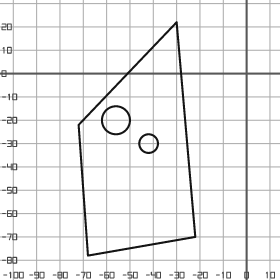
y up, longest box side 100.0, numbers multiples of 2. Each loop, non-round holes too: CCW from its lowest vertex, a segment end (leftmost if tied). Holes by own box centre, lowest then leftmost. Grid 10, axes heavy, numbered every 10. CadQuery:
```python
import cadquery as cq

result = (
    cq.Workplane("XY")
    .moveTo(-68.0, -78.0)
    .lineTo(-22.0, -70.0)
    .lineTo(-30.0, 22.0)
    .lineTo(-72.0, -22.0)
    .close()
    .moveTo(-42.0, -30.0)
    .circle(4.0)
    .moveTo(-56.0, -20.0)
    .circle(6.0)
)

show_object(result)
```